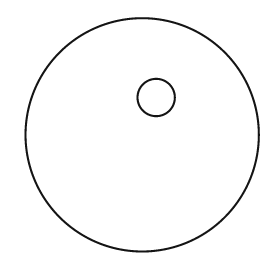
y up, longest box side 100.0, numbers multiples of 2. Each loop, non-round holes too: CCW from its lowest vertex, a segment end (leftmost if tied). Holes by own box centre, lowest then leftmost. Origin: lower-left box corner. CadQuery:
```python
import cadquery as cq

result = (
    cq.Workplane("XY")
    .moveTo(50.0, 50.0)
    .circle(50.0)
    .moveTo(56.0, 66.0)
    .circle(8.0)
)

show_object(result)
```